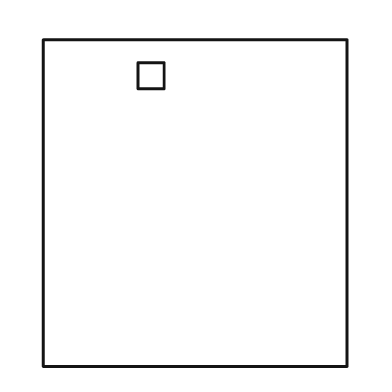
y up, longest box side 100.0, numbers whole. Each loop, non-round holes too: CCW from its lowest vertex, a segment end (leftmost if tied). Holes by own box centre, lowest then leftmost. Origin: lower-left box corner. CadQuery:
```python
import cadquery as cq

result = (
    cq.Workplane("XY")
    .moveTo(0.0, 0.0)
    .lineTo(93.0, 0.0)
    .lineTo(93.0, 100.0)
    .lineTo(0.0, 100.0)
    .close()
    .moveTo(29.0, 85.0)
    .lineTo(37.0, 85.0)
    .lineTo(37.0, 93.0)
    .lineTo(29.0, 93.0)
    .close()
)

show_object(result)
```